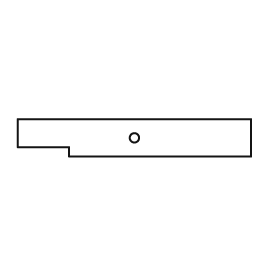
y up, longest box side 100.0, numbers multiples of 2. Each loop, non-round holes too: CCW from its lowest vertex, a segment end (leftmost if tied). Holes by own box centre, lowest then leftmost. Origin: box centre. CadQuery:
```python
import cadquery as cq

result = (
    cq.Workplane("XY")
    .moveTo(-28.0, -8.0)
    .lineTo(50.0, -8.0)
    .lineTo(50.0, 8.0)
    .lineTo(-50.0, 8.0)
    .lineTo(-50.0, -4.0)
    .lineTo(-28.0, -4.0)
    .close()
    .moveTo(0.0, 0.0)
    .circle(2.0)
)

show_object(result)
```